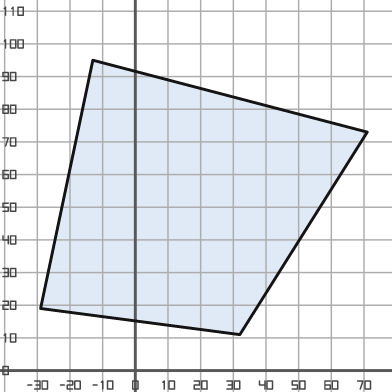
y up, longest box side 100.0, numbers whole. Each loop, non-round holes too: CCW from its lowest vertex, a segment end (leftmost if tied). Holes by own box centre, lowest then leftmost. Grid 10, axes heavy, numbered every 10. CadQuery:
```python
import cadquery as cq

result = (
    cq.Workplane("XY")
    .moveTo(32.0, 11.0)
    .lineTo(71.0, 73.0)
    .lineTo(-13.0, 95.0)
    .lineTo(-29.0, 19.0)
    .close()
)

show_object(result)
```